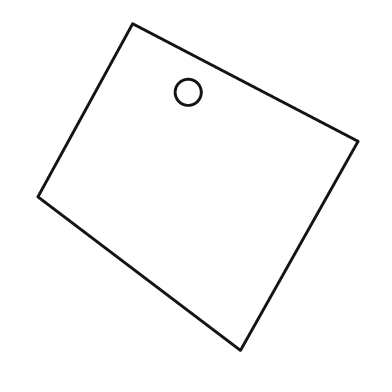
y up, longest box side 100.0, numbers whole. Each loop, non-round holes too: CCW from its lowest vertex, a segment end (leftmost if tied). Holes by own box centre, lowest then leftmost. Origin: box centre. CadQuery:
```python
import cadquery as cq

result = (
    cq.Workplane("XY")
    .moveTo(13.0, -50.0)
    .lineTo(49.0, 14.0)
    .lineTo(-20.0, 50.0)
    .lineTo(-49.0, -3.0)
    .close()
    .moveTo(-3.0, 29.0)
    .circle(4.0)
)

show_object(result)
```